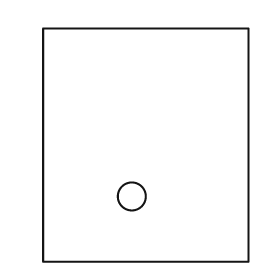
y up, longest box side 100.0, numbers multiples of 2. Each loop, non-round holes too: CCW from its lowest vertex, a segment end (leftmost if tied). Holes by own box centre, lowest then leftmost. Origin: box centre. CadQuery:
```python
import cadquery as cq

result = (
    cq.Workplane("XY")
    .moveTo(-44.0, -50.0)
    .lineTo(44.0, -50.0)
    .lineTo(44.0, 50.0)
    .lineTo(-44.0, 50.0)
    .close()
    .moveTo(-6.0, -22.0)
    .circle(6.0)
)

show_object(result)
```